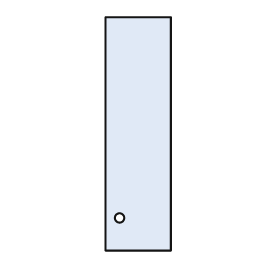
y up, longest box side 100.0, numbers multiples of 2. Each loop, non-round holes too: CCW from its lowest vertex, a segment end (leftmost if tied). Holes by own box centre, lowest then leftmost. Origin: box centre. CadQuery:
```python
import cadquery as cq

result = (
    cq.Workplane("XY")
    .moveTo(-14.0, -50.0)
    .lineTo(14.0, -50.0)
    .lineTo(14.0, 50.0)
    .lineTo(-14.0, 50.0)
    .close()
    .moveTo(-8.0, -36.0)
    .circle(2.0)
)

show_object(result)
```